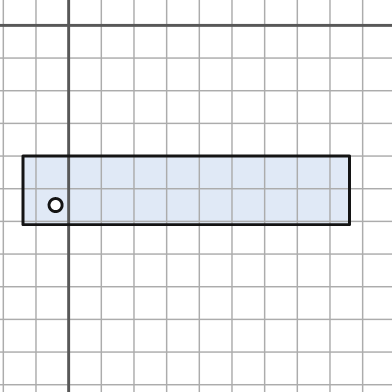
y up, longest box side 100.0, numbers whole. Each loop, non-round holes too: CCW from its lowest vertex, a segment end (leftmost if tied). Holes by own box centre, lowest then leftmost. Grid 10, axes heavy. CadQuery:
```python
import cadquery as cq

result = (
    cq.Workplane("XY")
    .moveTo(-14.0, -61.0)
    .lineTo(86.0, -61.0)
    .lineTo(86.0, -40.0)
    .lineTo(-14.0, -40.0)
    .close()
    .moveTo(-4.0, -55.0)
    .circle(2.0)
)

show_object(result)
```